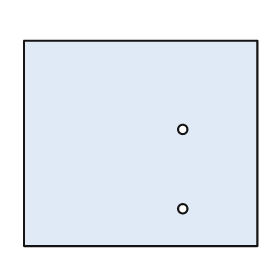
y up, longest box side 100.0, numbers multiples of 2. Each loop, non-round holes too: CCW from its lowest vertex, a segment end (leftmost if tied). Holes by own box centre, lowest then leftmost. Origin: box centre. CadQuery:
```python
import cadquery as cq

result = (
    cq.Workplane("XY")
    .moveTo(-50.0, -44.0)
    .lineTo(50.0, -44.0)
    .lineTo(50.0, 44.0)
    .lineTo(-50.0, 44.0)
    .close()
    .moveTo(18.0, -28.0)
    .circle(2.0)
    .moveTo(18.0, 6.0)
    .circle(2.0)
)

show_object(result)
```